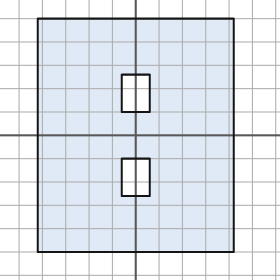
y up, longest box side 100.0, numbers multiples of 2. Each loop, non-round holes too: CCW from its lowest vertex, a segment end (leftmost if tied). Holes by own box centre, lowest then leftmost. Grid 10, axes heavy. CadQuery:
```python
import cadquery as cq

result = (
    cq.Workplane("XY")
    .moveTo(-42.0, -50.0)
    .lineTo(42.0, -50.0)
    .lineTo(42.0, 50.0)
    .lineTo(-42.0, 50.0)
    .close()
    .moveTo(-6.0, -26.0)
    .lineTo(6.0, -26.0)
    .lineTo(6.0, -10.0)
    .lineTo(-6.0, -10.0)
    .close()
    .moveTo(-6.0, 10.0)
    .lineTo(6.0, 10.0)
    .lineTo(6.0, 26.0)
    .lineTo(-6.0, 26.0)
    .close()
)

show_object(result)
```